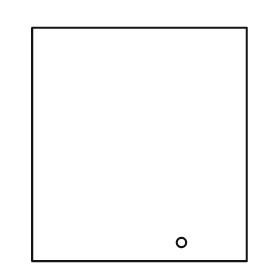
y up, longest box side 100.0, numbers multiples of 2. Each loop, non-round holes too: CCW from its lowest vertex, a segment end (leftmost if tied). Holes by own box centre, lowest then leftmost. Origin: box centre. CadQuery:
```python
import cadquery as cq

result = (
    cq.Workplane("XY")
    .moveTo(-46.0, -50.0)
    .lineTo(46.0, -50.0)
    .lineTo(46.0, 50.0)
    .lineTo(-46.0, 50.0)
    .close()
    .moveTo(18.0, -42.0)
    .circle(2.0)
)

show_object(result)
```